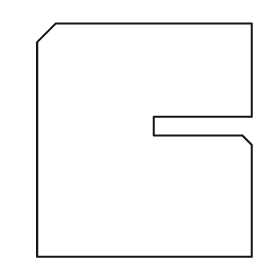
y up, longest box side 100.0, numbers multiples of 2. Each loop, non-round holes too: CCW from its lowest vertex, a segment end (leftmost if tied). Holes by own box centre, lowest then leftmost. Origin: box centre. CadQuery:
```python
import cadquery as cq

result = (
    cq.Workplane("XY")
    .moveTo(-46.0, -50.0)
    .lineTo(46.0, -50.0)
    .lineTo(46.0, -2.0)
    .lineTo(42.0, 2.0)
    .lineTo(4.0, 2.0)
    .lineTo(4.0, 10.0)
    .lineTo(46.0, 10.0)
    .lineTo(46.0, 50.0)
    .lineTo(-38.0, 50.0)
    .lineTo(-46.0, 42.0)
    .close()
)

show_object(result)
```